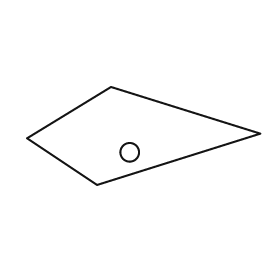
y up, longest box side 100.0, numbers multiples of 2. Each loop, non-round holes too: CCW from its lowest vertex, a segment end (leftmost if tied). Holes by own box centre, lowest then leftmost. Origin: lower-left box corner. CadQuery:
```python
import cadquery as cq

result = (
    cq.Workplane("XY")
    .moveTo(30.0, 0.0)
    .lineTo(100.0, 22.0)
    .lineTo(36.0, 42.0)
    .lineTo(0.0, 20.0)
    .close()
    .moveTo(44.0, 14.0)
    .circle(4.0)
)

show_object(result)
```